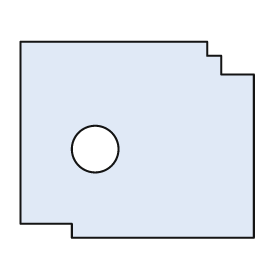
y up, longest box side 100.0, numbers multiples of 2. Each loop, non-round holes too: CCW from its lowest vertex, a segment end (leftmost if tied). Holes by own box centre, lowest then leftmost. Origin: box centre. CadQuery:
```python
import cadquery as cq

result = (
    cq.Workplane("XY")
    .moveTo(-28.0, -42.0)
    .lineTo(50.0, -42.0)
    .lineTo(50.0, 28.0)
    .lineTo(36.0, 28.0)
    .lineTo(36.0, 36.0)
    .lineTo(30.0, 36.0)
    .lineTo(30.0, 42.0)
    .lineTo(-50.0, 42.0)
    .lineTo(-50.0, -36.0)
    .lineTo(-28.0, -36.0)
    .close()
    .moveTo(-18.0, -4.0)
    .circle(10.0)
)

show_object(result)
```